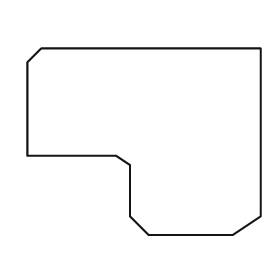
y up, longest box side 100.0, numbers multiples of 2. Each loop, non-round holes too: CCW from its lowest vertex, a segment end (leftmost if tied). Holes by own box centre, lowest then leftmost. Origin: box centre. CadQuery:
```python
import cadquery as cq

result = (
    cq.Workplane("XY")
    .moveTo(2.0, -40.0)
    .lineTo(38.0, -40.0)
    .lineTo(50.0, -32.0)
    .lineTo(50.0, 40.0)
    .lineTo(-44.0, 40.0)
    .lineTo(-50.0, 34.0)
    .lineTo(-50.0, -6.0)
    .lineTo(-12.0, -6.0)
    .lineTo(-6.0, -10.0)
    .lineTo(-6.0, -32.0)
    .close()
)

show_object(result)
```